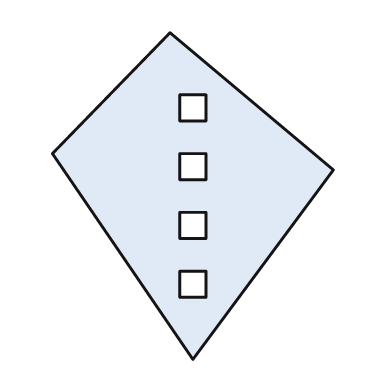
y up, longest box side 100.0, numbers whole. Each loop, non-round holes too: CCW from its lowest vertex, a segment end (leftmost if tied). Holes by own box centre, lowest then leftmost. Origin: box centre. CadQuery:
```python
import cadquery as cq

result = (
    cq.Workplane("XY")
    .moveTo(0.0, -50.0)
    .lineTo(43.0, 8.0)
    .lineTo(-7.0, 50.0)
    .lineTo(-43.0, 13.0)
    .close()
    .moveTo(-4.0, -31.0)
    .lineTo(4.0, -31.0)
    .lineTo(4.0, -23.0)
    .lineTo(-4.0, -23.0)
    .close()
    .moveTo(-4.0, -13.0)
    .lineTo(4.0, -13.0)
    .lineTo(4.0, -5.0)
    .lineTo(-4.0, -5.0)
    .close()
    .moveTo(-4.0, 5.0)
    .lineTo(4.0, 5.0)
    .lineTo(4.0, 13.0)
    .lineTo(-4.0, 13.0)
    .close()
    .moveTo(-4.0, 23.0)
    .lineTo(4.0, 23.0)
    .lineTo(4.0, 31.0)
    .lineTo(-4.0, 31.0)
    .close()
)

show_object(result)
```